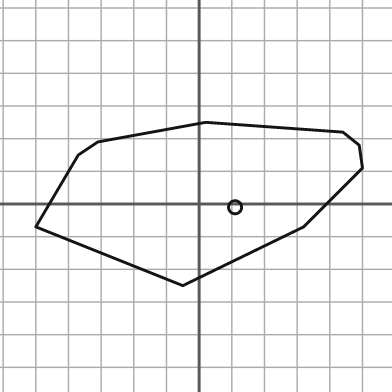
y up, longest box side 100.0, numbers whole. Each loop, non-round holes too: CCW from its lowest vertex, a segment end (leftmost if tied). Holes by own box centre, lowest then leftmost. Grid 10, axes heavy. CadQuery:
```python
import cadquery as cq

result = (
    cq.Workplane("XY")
    .moveTo(-5.0, -25.0)
    .lineTo(32.0, -7.0)
    .lineTo(50.0, 11.0)
    .lineTo(49.0, 18.0)
    .lineTo(44.0, 22.0)
    .lineTo(2.0, 25.0)
    .lineTo(-31.0, 19.0)
    .lineTo(-37.0, 15.0)
    .lineTo(-50.0, -7.0)
    .close()
    .moveTo(11.0, -1.0)
    .circle(2.0)
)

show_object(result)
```